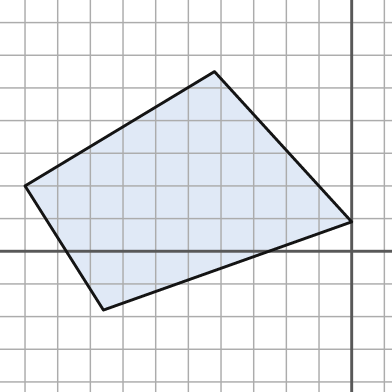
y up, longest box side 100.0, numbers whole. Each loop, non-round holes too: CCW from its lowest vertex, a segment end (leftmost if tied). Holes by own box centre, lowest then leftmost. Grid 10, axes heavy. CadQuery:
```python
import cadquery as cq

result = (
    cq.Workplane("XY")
    .moveTo(-76.0, -18.0)
    .lineTo(0.0, 9.0)
    .lineTo(-42.0, 55.0)
    .lineTo(-100.0, 20.0)
    .close()
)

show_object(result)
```